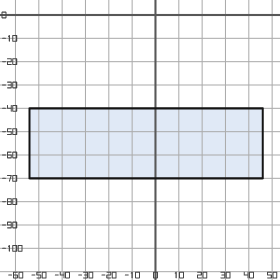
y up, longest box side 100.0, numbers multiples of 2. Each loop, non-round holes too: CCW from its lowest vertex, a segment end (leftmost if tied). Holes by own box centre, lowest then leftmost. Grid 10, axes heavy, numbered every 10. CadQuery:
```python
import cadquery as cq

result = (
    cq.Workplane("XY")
    .moveTo(-54.0, -70.0)
    .lineTo(46.0, -70.0)
    .lineTo(46.0, -40.0)
    .lineTo(-54.0, -40.0)
    .close()
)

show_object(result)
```